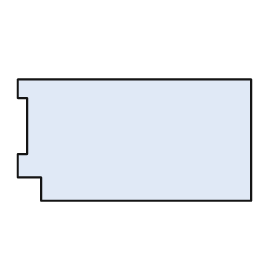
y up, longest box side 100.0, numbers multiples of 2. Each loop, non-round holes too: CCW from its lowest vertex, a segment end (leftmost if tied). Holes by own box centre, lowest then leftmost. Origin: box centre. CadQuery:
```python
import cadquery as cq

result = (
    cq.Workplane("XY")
    .moveTo(-40.0, -26.0)
    .lineTo(50.0, -26.0)
    .lineTo(50.0, 26.0)
    .lineTo(-50.0, 26.0)
    .lineTo(-50.0, 18.0)
    .lineTo(-46.0, 18.0)
    .lineTo(-46.0, -6.0)
    .lineTo(-50.0, -6.0)
    .lineTo(-50.0, -16.0)
    .lineTo(-40.0, -16.0)
    .close()
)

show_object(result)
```